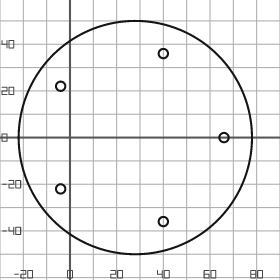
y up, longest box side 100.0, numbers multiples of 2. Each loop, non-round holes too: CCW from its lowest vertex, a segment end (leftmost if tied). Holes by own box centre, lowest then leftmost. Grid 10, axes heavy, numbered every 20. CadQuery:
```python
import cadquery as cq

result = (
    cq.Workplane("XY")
    .moveTo(28.0, 0.0)
    .circle(50.0)
    .moveTo(40.0, -36.0)
    .circle(2.0)
    .moveTo(-4.0, -22.0)
    .circle(2.0)
    .moveTo(66.0, 0.0)
    .circle(2.0)
    .moveTo(-4.0, 22.0)
    .circle(2.0)
    .moveTo(40.0, 36.0)
    .circle(2.0)
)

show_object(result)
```